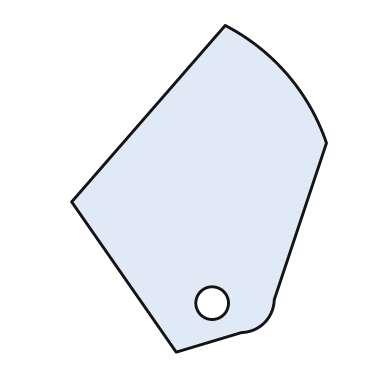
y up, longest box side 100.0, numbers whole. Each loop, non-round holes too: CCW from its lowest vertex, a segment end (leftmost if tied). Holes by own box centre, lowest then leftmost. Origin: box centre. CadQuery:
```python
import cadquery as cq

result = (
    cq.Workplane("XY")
    .moveTo(-7.0, -50.0)
    .lineTo(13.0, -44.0)
    .threePointArc((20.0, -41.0), (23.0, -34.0))
    .lineTo(39.0, 14.0)
    .threePointArc((27.0, 35.0), (8.0, 50.0))
    .lineTo(-39.0, -4.0)
    .close()
    .moveTo(4.0, -35.0)
    .circle(5.0)
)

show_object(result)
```